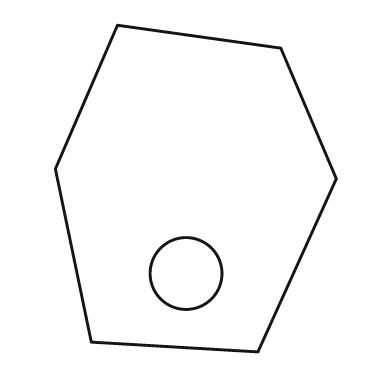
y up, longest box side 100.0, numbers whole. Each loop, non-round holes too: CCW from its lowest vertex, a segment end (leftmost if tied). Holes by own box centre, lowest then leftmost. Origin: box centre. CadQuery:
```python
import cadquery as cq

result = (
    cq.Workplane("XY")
    .moveTo(19.0, -50.0)
    .lineTo(43.0, 3.0)
    .lineTo(26.0, 43.0)
    .lineTo(-24.0, 50.0)
    .lineTo(-43.0, 6.0)
    .lineTo(-32.0, -47.0)
    .close()
    .moveTo(-3.0, -26.0)
    .circle(11.0)
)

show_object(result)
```